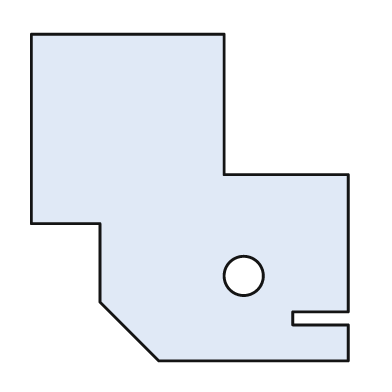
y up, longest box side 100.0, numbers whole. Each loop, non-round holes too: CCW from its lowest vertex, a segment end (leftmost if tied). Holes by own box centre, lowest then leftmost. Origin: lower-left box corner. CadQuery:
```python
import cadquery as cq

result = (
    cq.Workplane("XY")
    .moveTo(39.0, 0.0)
    .lineTo(97.0, 0.0)
    .lineTo(97.0, 11.0)
    .lineTo(80.0, 11.0)
    .lineTo(80.0, 15.0)
    .lineTo(97.0, 15.0)
    .lineTo(97.0, 57.0)
    .lineTo(59.0, 57.0)
    .lineTo(59.0, 100.0)
    .lineTo(0.0, 100.0)
    .lineTo(0.0, 42.0)
    .lineTo(21.0, 42.0)
    .lineTo(21.0, 18.0)
    .close()
    .moveTo(65.0, 26.0)
    .circle(6.0)
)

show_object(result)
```